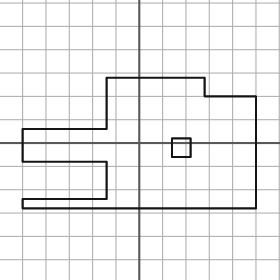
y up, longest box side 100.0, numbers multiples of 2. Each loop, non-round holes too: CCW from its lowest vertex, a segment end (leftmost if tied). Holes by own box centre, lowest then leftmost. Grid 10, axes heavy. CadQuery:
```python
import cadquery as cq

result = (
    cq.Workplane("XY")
    .moveTo(-50.0, -28.0)
    .lineTo(50.0, -28.0)
    .lineTo(50.0, 20.0)
    .lineTo(28.0, 20.0)
    .lineTo(28.0, 28.0)
    .lineTo(-14.0, 28.0)
    .lineTo(-14.0, 6.0)
    .lineTo(-50.0, 6.0)
    .lineTo(-50.0, -8.0)
    .lineTo(-14.0, -8.0)
    .lineTo(-14.0, -24.0)
    .lineTo(-50.0, -24.0)
    .close()
    .moveTo(14.0, -6.0)
    .lineTo(22.0, -6.0)
    .lineTo(22.0, 2.0)
    .lineTo(14.0, 2.0)
    .close()
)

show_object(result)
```